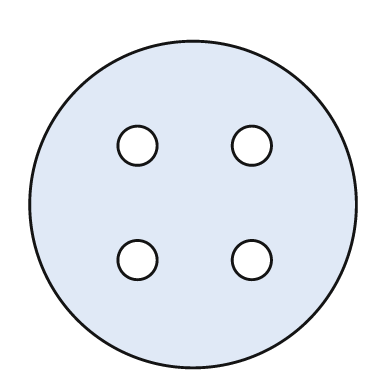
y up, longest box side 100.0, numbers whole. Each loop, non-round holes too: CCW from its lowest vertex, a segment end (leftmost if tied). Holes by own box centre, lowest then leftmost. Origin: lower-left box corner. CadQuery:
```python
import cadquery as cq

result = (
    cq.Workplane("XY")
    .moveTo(50.0, 50.0)
    .circle(50.0)
    .moveTo(33.0, 33.0)
    .circle(6.0)
    .moveTo(68.0, 33.0)
    .circle(6.0)
    .moveTo(33.0, 68.0)
    .circle(6.0)
    .moveTo(68.0, 68.0)
    .circle(6.0)
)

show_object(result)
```